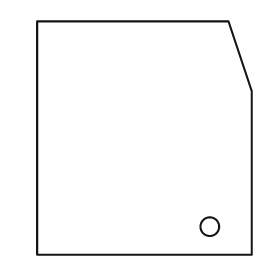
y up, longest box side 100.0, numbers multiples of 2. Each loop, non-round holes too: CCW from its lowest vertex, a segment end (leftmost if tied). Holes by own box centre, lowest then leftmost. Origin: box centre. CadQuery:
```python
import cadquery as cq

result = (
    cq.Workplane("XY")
    .moveTo(-46.0, -50.0)
    .lineTo(46.0, -50.0)
    .lineTo(46.0, 20.0)
    .lineTo(36.0, 50.0)
    .lineTo(-46.0, 50.0)
    .close()
    .moveTo(28.0, -38.0)
    .circle(4.0)
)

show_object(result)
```